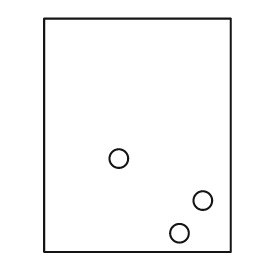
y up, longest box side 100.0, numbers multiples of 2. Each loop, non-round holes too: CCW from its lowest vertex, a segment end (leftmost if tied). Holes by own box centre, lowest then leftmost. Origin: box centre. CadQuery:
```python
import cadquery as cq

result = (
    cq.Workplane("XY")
    .moveTo(-40.0, -50.0)
    .lineTo(40.0, -50.0)
    .lineTo(40.0, 50.0)
    .lineTo(-40.0, 50.0)
    .close()
    .moveTo(18.0, -42.0)
    .circle(4.0)
    .moveTo(28.0, -28.0)
    .circle(4.0)
    .moveTo(-8.0, -10.0)
    .circle(4.0)
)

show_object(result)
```